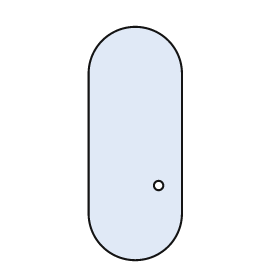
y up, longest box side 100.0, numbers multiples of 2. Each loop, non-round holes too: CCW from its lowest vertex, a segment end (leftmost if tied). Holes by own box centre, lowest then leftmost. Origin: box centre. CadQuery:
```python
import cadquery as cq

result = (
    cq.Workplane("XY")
    .moveTo(-20.0, -30.0)
    .threePointArc((0.0, -50.0), (20.0, -30.0))
    .lineTo(20.0, 30.0)
    .threePointArc((0.0, 50.0), (-20.0, 30.0))
    .close()
    .moveTo(10.0, -18.0)
    .circle(2.0)
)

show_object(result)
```